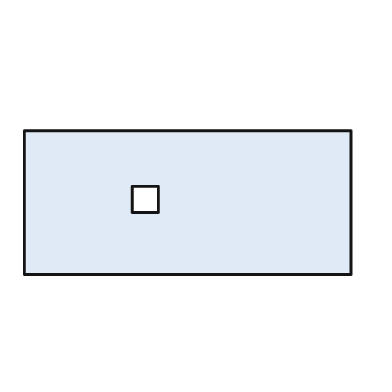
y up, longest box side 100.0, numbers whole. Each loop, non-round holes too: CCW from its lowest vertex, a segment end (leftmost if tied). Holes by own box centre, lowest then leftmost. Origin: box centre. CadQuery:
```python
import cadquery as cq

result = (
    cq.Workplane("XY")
    .moveTo(-50.0, -22.0)
    .lineTo(50.0, -22.0)
    .lineTo(50.0, 22.0)
    .lineTo(-50.0, 22.0)
    .close()
    .moveTo(-17.0, -3.0)
    .lineTo(-9.0, -3.0)
    .lineTo(-9.0, 5.0)
    .lineTo(-17.0, 5.0)
    .close()
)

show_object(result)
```